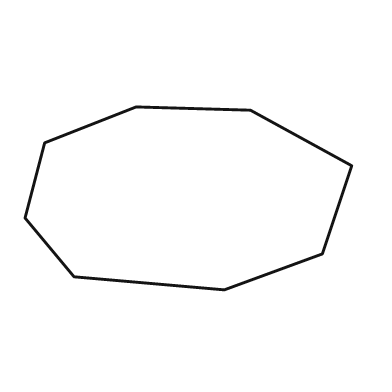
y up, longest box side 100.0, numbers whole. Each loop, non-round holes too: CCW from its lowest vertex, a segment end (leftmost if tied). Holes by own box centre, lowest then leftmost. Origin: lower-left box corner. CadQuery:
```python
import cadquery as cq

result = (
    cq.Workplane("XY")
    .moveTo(61.0, 0.0)
    .lineTo(91.0, 11.0)
    .lineTo(100.0, 38.0)
    .lineTo(69.0, 55.0)
    .lineTo(34.0, 56.0)
    .lineTo(6.0, 45.0)
    .lineTo(0.0, 22.0)
    .lineTo(15.0, 4.0)
    .close()
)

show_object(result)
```